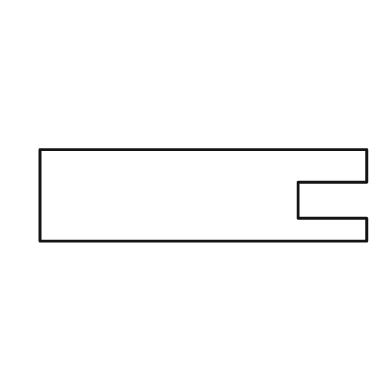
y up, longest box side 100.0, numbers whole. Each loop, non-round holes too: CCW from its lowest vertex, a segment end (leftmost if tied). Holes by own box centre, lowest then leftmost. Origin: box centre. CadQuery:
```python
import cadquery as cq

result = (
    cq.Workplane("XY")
    .moveTo(-50.0, -14.0)
    .lineTo(50.0, -14.0)
    .lineTo(50.0, -7.0)
    .lineTo(29.0, -7.0)
    .lineTo(29.0, 4.0)
    .lineTo(50.0, 4.0)
    .lineTo(50.0, 14.0)
    .lineTo(-50.0, 14.0)
    .close()
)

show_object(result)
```